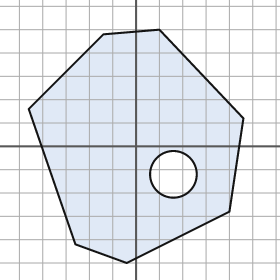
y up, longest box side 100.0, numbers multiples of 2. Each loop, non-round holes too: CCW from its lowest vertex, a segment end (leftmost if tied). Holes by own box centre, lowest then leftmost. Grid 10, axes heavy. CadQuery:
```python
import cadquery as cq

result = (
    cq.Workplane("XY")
    .moveTo(-4.0, -50.0)
    .lineTo(40.0, -28.0)
    .lineTo(46.0, 12.0)
    .lineTo(10.0, 50.0)
    .lineTo(-14.0, 48.0)
    .lineTo(-46.0, 16.0)
    .lineTo(-26.0, -42.0)
    .close()
    .moveTo(16.0, -12.0)
    .circle(10.0)
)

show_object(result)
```